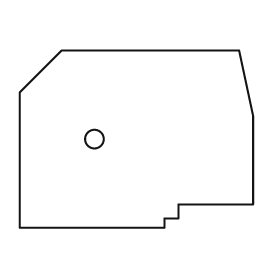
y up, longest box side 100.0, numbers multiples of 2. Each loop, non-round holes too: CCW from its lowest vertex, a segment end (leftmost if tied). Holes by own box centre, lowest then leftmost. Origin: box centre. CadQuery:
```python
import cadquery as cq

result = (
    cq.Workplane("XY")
    .moveTo(-50.0, -38.0)
    .lineTo(12.0, -38.0)
    .lineTo(12.0, -34.0)
    .lineTo(18.0, -34.0)
    .lineTo(18.0, -28.0)
    .lineTo(50.0, -28.0)
    .lineTo(50.0, 10.0)
    .lineTo(44.0, 38.0)
    .lineTo(-32.0, 38.0)
    .lineTo(-50.0, 20.0)
    .close()
    .moveTo(-18.0, 0.0)
    .circle(4.0)
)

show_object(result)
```